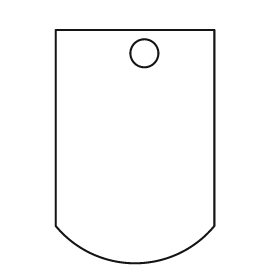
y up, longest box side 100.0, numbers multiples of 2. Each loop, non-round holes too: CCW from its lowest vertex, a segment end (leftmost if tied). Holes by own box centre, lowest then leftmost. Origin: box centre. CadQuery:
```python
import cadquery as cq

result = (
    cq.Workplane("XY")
    .moveTo(-34.0, -34.0)
    .threePointArc((0.0, -50.0), (34.0, -34.0))
    .lineTo(34.0, 50.0)
    .lineTo(-34.0, 50.0)
    .close()
    .moveTo(4.0, 40.0)
    .circle(6.0)
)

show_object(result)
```